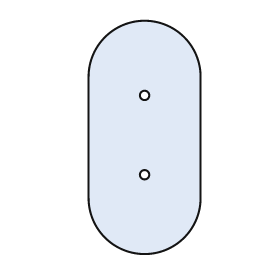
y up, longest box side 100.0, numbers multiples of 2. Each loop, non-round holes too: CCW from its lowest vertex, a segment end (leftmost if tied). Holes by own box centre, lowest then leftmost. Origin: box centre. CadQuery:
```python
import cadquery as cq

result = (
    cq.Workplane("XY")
    .moveTo(-24.0, -26.0)
    .threePointArc((0.0, -50.0), (24.0, -26.0))
    .lineTo(24.0, 26.0)
    .threePointArc((0.0, 50.0), (-24.0, 26.0))
    .close()
    .moveTo(0.0, -16.0)
    .circle(2.0)
    .moveTo(0.0, 18.0)
    .circle(2.0)
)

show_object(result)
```